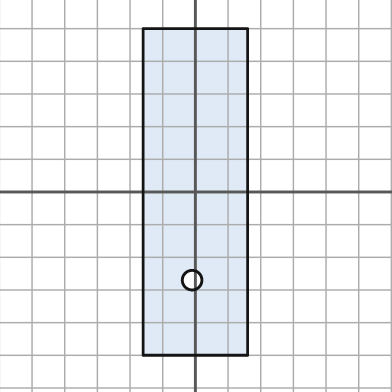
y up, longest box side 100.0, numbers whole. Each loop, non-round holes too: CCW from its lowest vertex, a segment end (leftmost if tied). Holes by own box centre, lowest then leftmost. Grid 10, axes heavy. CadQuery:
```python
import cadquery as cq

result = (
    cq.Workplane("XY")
    .moveTo(-16.0, -50.0)
    .lineTo(16.0, -50.0)
    .lineTo(16.0, 50.0)
    .lineTo(-16.0, 50.0)
    .close()
    .moveTo(-1.0, -27.0)
    .circle(3.0)
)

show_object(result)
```